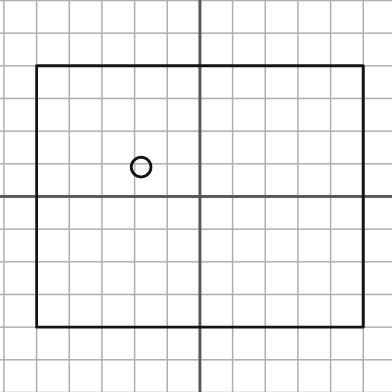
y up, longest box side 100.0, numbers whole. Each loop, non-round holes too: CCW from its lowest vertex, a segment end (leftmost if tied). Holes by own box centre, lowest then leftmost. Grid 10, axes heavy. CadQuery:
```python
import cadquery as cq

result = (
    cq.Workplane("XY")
    .moveTo(-50.0, -40.0)
    .lineTo(50.0, -40.0)
    .lineTo(50.0, 40.0)
    .lineTo(-50.0, 40.0)
    .close()
    .moveTo(-18.0, 9.0)
    .circle(3.0)
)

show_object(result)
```